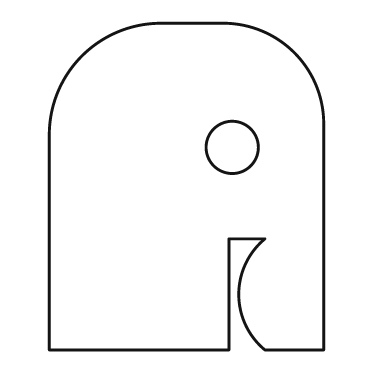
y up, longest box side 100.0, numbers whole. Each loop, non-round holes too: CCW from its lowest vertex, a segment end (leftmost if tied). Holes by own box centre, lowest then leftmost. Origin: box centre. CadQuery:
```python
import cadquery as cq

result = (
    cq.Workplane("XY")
    .moveTo(-42.0, -50.0)
    .lineTo(13.0, -50.0)
    .lineTo(13.0, -16.0)
    .lineTo(24.0, -16.0)
    .threePointArc((16.0, -33.0), (24.0, -50.0))
    .lineTo(42.0, -50.0)
    .lineTo(42.0, 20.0)
    .threePointArc((33.0, 41.0), (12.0, 50.0))
    .lineTo(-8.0, 50.0)
    .threePointArc((-32.0, 40.0), (-42.0, 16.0))
    .close()
    .moveTo(14.0, 12.0)
    .circle(8.0)
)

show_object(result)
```